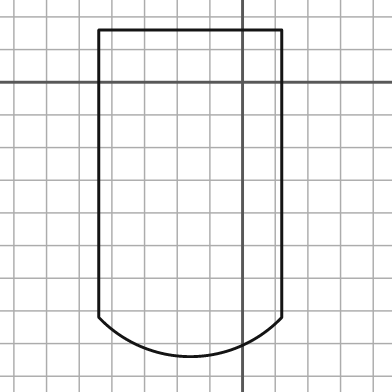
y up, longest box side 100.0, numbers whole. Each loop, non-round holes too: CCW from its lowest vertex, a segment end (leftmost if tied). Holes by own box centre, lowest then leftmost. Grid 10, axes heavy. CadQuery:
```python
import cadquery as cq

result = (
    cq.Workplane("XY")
    .moveTo(-44.0, -72.0)
    .threePointArc((-16.0, -84.0), (12.0, -72.0))
    .lineTo(12.0, 16.0)
    .lineTo(-44.0, 16.0)
    .close()
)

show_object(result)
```